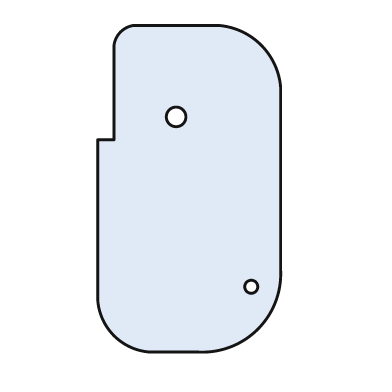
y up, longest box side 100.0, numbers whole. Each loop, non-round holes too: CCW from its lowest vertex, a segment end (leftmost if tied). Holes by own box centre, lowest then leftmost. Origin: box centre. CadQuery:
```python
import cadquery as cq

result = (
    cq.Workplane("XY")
    .moveTo(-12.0, -50.0)
    .lineTo(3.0, -50.0)
    .threePointArc((21.0, -43.0), (28.0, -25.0))
    .lineTo(28.0, 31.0)
    .threePointArc((22.0, 44.0), (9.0, 50.0))
    .lineTo(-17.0, 50.0)
    .threePointArc((-21.0, 48.0), (-23.0, 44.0))
    .lineTo(-23.0, 15.0)
    .lineTo(-28.0, 15.0)
    .lineTo(-28.0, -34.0)
    .threePointArc((-23.0, -45.0), (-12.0, -50.0))
    .close()
    .moveTo(19.0, -30.0)
    .circle(2.0)
    .moveTo(-4.0, 22.0)
    .circle(3.0)
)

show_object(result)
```